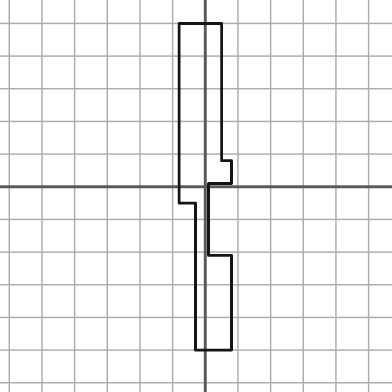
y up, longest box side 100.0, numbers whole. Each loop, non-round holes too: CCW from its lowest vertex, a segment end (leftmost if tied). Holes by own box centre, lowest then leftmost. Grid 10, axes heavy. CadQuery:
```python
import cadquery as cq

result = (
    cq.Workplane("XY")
    .moveTo(-3.0, -50.0)
    .lineTo(8.0, -50.0)
    .lineTo(8.0, -21.0)
    .lineTo(1.0, -21.0)
    .lineTo(1.0, 1.0)
    .lineTo(8.0, 1.0)
    .lineTo(8.0, 8.0)
    .lineTo(5.0, 8.0)
    .lineTo(5.0, 50.0)
    .lineTo(-8.0, 50.0)
    .lineTo(-8.0, -5.0)
    .lineTo(-3.0, -5.0)
    .close()
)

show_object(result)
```